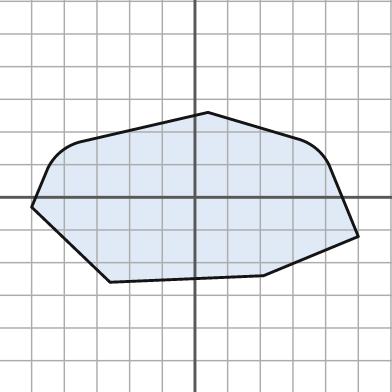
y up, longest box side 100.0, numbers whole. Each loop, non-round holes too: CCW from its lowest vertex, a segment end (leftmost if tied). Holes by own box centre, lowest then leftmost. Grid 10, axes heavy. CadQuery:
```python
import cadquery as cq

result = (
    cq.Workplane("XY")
    .moveTo(-26.0, -26.0)
    .lineTo(21.0, -24.0)
    .lineTo(50.0, -12.0)
    .lineTo(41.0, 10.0)
    .threePointArc((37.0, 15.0), (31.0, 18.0))
    .lineTo(4.0, 26.0)
    .lineTo(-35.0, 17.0)
    .threePointArc((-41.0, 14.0), (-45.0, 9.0))
    .lineTo(-50.0, -3.0)
    .close()
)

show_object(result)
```